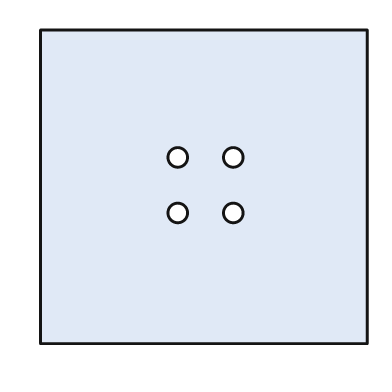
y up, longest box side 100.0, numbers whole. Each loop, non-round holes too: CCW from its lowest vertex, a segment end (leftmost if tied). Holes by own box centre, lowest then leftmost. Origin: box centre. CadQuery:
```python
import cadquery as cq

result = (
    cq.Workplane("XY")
    .moveTo(-50.0, -48.0)
    .lineTo(50.0, -48.0)
    .lineTo(50.0, 48.0)
    .lineTo(-50.0, 48.0)
    .close()
    .moveTo(-8.0, -8.0)
    .circle(3.0)
    .moveTo(9.0, -8.0)
    .circle(3.0)
    .moveTo(-8.0, 9.0)
    .circle(3.0)
    .moveTo(9.0, 9.0)
    .circle(3.0)
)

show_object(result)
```